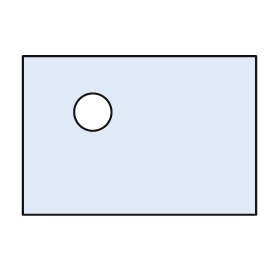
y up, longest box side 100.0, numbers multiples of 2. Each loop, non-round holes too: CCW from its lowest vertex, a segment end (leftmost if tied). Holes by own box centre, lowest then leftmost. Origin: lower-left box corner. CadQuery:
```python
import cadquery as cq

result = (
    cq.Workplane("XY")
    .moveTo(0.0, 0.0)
    .lineTo(100.0, 0.0)
    .lineTo(100.0, 68.0)
    .lineTo(0.0, 68.0)
    .close()
    .moveTo(30.0, 44.0)
    .circle(8.0)
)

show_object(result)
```